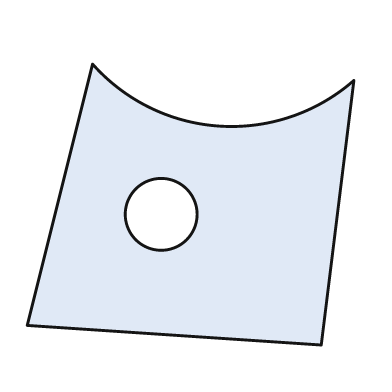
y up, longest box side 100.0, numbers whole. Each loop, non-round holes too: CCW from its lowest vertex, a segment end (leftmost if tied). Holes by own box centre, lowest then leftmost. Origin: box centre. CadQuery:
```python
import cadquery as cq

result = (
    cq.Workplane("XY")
    .moveTo(40.0, -43.0)
    .lineTo(50.0, 38.0)
    .threePointArc((9.0, 24.0), (-30.0, 43.0))
    .lineTo(-50.0, -37.0)
    .close()
    .moveTo(-9.0, -3.0)
    .circle(11.0)
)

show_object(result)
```